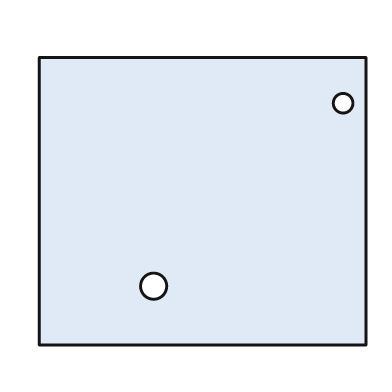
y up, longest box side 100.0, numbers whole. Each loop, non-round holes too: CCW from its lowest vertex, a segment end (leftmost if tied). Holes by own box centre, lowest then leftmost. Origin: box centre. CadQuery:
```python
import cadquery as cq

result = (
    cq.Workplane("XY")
    .moveTo(-50.0, -44.0)
    .lineTo(50.0, -44.0)
    .lineTo(50.0, 44.0)
    .lineTo(-50.0, 44.0)
    .close()
    .moveTo(-15.0, -26.0)
    .circle(4.0)
    .moveTo(43.0, 30.0)
    .circle(3.0)
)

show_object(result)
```